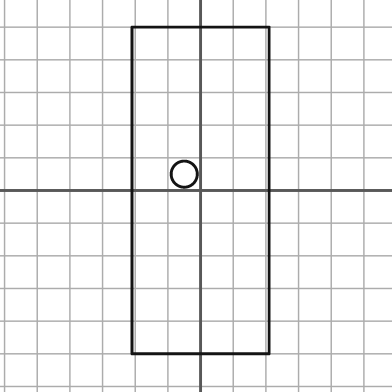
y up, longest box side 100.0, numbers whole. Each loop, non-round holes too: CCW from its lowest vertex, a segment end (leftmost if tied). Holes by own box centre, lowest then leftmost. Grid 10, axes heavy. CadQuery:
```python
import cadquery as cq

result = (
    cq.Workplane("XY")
    .moveTo(-21.0, -50.0)
    .lineTo(21.0, -50.0)
    .lineTo(21.0, 50.0)
    .lineTo(-21.0, 50.0)
    .close()
    .moveTo(-5.0, 5.0)
    .circle(4.0)
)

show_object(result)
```